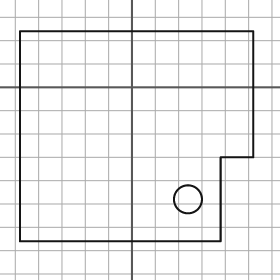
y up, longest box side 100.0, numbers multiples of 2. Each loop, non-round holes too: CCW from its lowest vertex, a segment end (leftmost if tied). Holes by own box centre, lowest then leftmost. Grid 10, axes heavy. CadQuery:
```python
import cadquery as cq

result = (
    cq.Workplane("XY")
    .moveTo(-48.0, -66.0)
    .lineTo(38.0, -66.0)
    .lineTo(38.0, -30.0)
    .lineTo(52.0, -30.0)
    .lineTo(52.0, 24.0)
    .lineTo(-48.0, 24.0)
    .close()
    .moveTo(24.0, -48.0)
    .circle(6.0)
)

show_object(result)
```